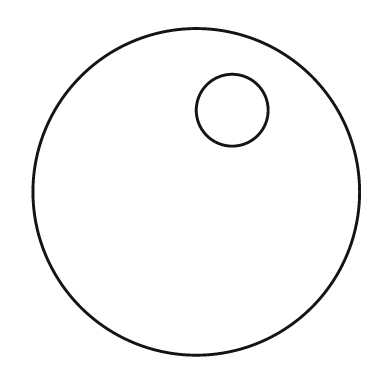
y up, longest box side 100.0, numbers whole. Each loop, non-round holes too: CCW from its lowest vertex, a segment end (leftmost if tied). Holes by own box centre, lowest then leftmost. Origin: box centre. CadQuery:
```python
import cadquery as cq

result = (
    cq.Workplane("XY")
    .moveTo(0.0, 0.0)
    .circle(50.0)
    .moveTo(11.0, 25.0)
    .circle(11.0)
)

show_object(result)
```